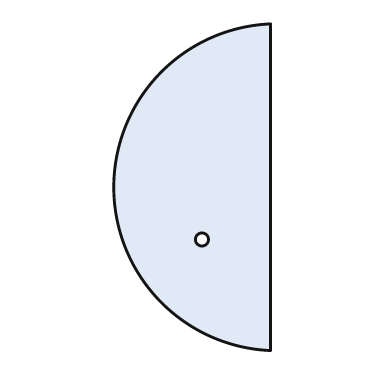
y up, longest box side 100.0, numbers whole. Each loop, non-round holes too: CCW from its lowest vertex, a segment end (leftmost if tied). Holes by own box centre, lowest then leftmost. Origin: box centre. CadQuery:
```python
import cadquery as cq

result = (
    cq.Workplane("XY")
    .moveTo(24.0, -50.0)
    .lineTo(24.0, 50.0)
    .threePointArc((-24.0, 0.0), (24.0, -50.0))
    .close()
    .moveTo(3.0, -16.0)
    .circle(2.0)
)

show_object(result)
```